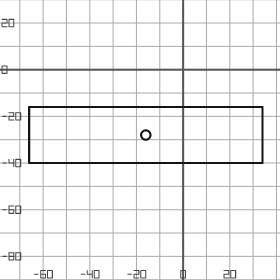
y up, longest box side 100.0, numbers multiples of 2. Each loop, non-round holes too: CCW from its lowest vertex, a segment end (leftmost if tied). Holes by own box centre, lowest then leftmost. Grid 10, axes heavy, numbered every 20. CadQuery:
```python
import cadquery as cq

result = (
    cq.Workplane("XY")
    .moveTo(-66.0, -40.0)
    .lineTo(34.0, -40.0)
    .lineTo(34.0, -16.0)
    .lineTo(-66.0, -16.0)
    .close()
    .moveTo(-16.0, -28.0)
    .circle(2.0)
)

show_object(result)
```